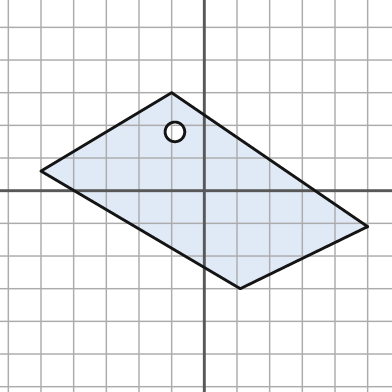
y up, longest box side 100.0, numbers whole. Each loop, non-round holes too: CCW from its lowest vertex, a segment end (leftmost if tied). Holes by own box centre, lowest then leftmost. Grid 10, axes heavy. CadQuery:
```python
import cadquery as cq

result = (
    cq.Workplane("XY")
    .moveTo(11.0, -30.0)
    .lineTo(50.0, -11.0)
    .lineTo(-10.0, 30.0)
    .lineTo(-50.0, 6.0)
    .close()
    .moveTo(-9.0, 18.0)
    .circle(3.0)
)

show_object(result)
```